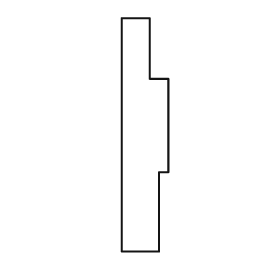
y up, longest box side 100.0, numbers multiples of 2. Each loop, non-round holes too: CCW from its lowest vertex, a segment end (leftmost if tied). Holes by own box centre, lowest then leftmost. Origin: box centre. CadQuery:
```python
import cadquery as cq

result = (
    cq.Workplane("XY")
    .moveTo(-10.0, -50.0)
    .lineTo(6.0, -50.0)
    .lineTo(6.0, -16.0)
    .lineTo(10.0, -16.0)
    .lineTo(10.0, 24.0)
    .lineTo(2.0, 24.0)
    .lineTo(2.0, 50.0)
    .lineTo(-10.0, 50.0)
    .close()
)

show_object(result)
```